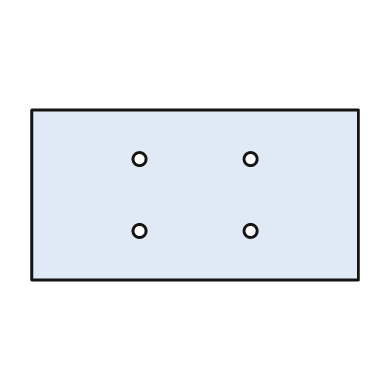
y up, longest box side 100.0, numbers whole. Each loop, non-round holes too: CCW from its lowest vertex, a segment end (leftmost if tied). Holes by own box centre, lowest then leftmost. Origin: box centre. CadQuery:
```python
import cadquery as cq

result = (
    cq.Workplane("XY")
    .moveTo(-50.0, -26.0)
    .lineTo(50.0, -26.0)
    .lineTo(50.0, 26.0)
    .lineTo(-50.0, 26.0)
    .close()
    .moveTo(-17.0, -11.0)
    .circle(2.0)
    .moveTo(17.0, -11.0)
    .circle(2.0)
    .moveTo(-17.0, 11.0)
    .circle(2.0)
    .moveTo(17.0, 11.0)
    .circle(2.0)
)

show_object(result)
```